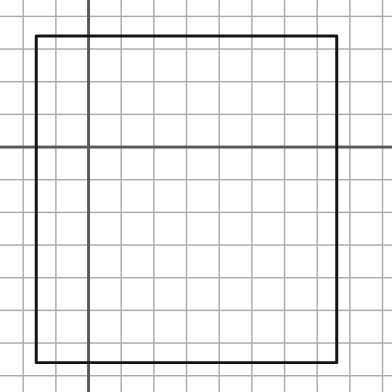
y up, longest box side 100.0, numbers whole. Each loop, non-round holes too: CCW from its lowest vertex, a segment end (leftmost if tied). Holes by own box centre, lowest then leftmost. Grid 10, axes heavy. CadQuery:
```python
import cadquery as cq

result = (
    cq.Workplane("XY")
    .moveTo(-16.0, -66.0)
    .lineTo(76.0, -66.0)
    .lineTo(76.0, 34.0)
    .lineTo(-16.0, 34.0)
    .close()
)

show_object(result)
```